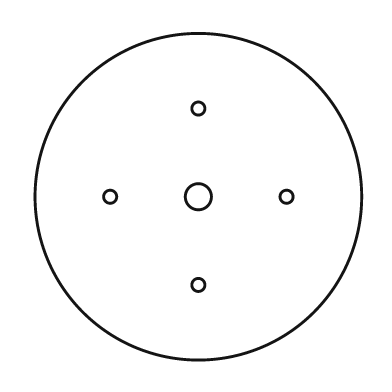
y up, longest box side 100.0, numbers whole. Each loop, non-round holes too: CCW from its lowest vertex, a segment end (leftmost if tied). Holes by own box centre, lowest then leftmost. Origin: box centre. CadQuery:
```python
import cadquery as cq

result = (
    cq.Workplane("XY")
    .moveTo(0.0, 0.0)
    .circle(50.0)
    .moveTo(0.0, -27.0)
    .circle(2.0)
    .moveTo(-27.0, 0.0)
    .circle(2.0)
    .moveTo(0.0, 0.0)
    .circle(4.0)
    .moveTo(27.0, 0.0)
    .circle(2.0)
    .moveTo(0.0, 27.0)
    .circle(2.0)
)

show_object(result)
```